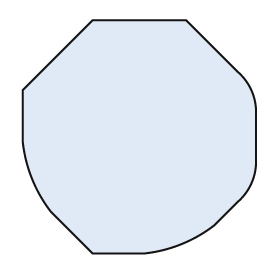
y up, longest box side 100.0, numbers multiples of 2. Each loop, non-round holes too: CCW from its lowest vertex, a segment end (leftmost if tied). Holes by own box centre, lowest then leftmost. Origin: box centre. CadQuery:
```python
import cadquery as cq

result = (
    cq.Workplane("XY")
    .moveTo(-20.0, -50.0)
    .lineTo(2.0, -50.0)
    .threePointArc((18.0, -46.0), (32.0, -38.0))
    .lineTo(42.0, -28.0)
    .threePointArc((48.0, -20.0), (50.0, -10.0))
    .lineTo(50.0, 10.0)
    .threePointArc((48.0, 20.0), (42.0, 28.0))
    .lineTo(20.0, 50.0)
    .lineTo(-20.0, 50.0)
    .lineTo(-50.0, 20.0)
    .lineTo(-50.0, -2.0)
    .threePointArc((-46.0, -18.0), (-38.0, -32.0))
    .close()
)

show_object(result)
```